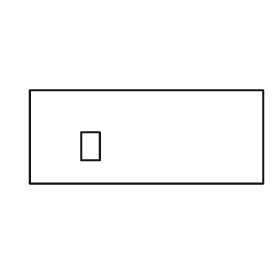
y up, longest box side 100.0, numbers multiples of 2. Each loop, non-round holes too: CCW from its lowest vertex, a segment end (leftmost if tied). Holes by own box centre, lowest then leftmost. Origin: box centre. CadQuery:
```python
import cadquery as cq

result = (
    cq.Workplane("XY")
    .moveTo(-50.0, -20.0)
    .lineTo(50.0, -20.0)
    .lineTo(50.0, 20.0)
    .lineTo(-50.0, 20.0)
    .close()
    .moveTo(-28.0, -10.0)
    .lineTo(-20.0, -10.0)
    .lineTo(-20.0, 2.0)
    .lineTo(-28.0, 2.0)
    .close()
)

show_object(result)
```